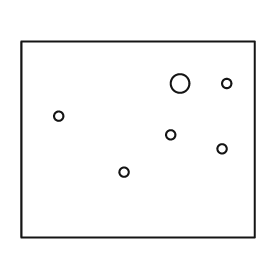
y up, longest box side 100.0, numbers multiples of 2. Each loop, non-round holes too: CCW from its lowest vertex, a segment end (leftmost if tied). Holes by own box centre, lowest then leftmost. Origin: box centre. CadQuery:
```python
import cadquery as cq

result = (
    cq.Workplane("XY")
    .moveTo(-50.0, -42.0)
    .lineTo(50.0, -42.0)
    .lineTo(50.0, 42.0)
    .lineTo(-50.0, 42.0)
    .close()
    .moveTo(-6.0, -14.0)
    .circle(2.0)
    .moveTo(36.0, -4.0)
    .circle(2.0)
    .moveTo(14.0, 2.0)
    .circle(2.0)
    .moveTo(-34.0, 10.0)
    .circle(2.0)
    .moveTo(18.0, 24.0)
    .circle(4.0)
    .moveTo(38.0, 24.0)
    .circle(2.0)
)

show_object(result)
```